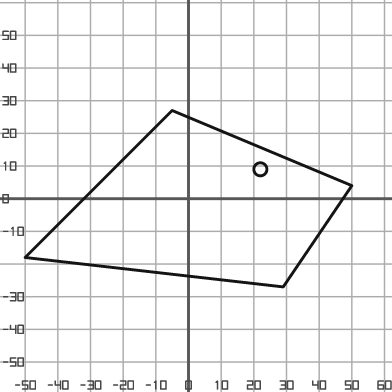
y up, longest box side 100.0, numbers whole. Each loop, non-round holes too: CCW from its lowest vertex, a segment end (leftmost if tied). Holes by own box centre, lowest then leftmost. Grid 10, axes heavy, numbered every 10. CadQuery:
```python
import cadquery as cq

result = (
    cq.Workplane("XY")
    .moveTo(29.0, -27.0)
    .lineTo(50.0, 4.0)
    .lineTo(-5.0, 27.0)
    .lineTo(-50.0, -18.0)
    .close()
    .moveTo(22.0, 9.0)
    .circle(2.0)
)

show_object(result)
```